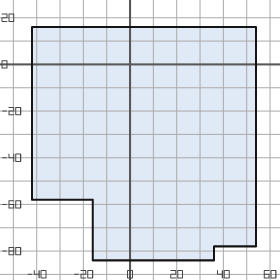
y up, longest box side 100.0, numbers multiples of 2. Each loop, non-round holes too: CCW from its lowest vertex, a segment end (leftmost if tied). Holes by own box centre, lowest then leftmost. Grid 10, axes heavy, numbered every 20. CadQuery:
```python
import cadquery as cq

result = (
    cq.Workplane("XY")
    .moveTo(-16.0, -84.0)
    .lineTo(36.0, -84.0)
    .lineTo(36.0, -78.0)
    .lineTo(54.0, -78.0)
    .lineTo(54.0, 16.0)
    .lineTo(-42.0, 16.0)
    .lineTo(-42.0, -58.0)
    .lineTo(-16.0, -58.0)
    .close()
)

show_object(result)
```